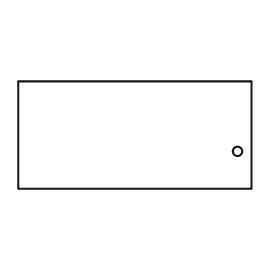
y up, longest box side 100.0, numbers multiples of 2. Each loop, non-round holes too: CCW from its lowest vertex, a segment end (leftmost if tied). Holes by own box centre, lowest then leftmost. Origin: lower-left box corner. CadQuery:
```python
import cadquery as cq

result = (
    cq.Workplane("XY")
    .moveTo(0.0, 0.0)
    .lineTo(100.0, 0.0)
    .lineTo(100.0, 46.0)
    .lineTo(0.0, 46.0)
    .close()
    .moveTo(94.0, 16.0)
    .circle(2.0)
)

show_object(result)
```